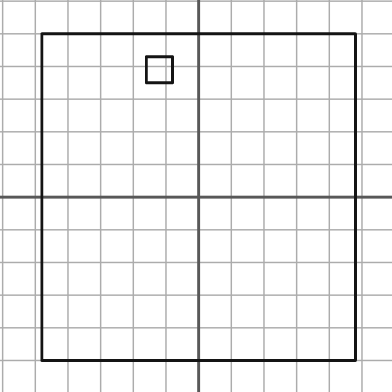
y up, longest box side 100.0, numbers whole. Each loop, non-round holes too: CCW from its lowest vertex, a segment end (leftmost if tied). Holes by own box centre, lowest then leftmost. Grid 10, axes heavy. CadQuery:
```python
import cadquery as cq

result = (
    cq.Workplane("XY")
    .moveTo(-48.0, -50.0)
    .lineTo(48.0, -50.0)
    .lineTo(48.0, 50.0)
    .lineTo(-48.0, 50.0)
    .close()
    .moveTo(-16.0, 35.0)
    .lineTo(-8.0, 35.0)
    .lineTo(-8.0, 43.0)
    .lineTo(-16.0, 43.0)
    .close()
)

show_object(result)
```